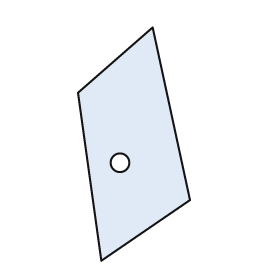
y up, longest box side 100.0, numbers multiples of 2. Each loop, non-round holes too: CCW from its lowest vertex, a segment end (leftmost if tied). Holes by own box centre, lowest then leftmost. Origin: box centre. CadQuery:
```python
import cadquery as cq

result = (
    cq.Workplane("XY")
    .moveTo(-14.0, -50.0)
    .lineTo(24.0, -24.0)
    .lineTo(8.0, 50.0)
    .lineTo(-24.0, 22.0)
    .close()
    .moveTo(-6.0, -8.0)
    .circle(4.0)
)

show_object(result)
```